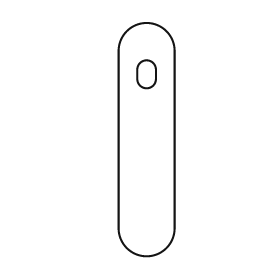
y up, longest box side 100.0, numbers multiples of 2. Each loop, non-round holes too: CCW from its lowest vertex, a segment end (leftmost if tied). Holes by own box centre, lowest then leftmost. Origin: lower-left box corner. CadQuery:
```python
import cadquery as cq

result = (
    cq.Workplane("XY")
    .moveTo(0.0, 12.0)
    .threePointArc((12.0, 0.0), (24.0, 12.0))
    .lineTo(24.0, 88.0)
    .threePointArc((12.0, 100.0), (0.0, 88.0))
    .close()
    .moveTo(8.0, 76.0)
    .threePointArc((12.0, 72.0), (16.0, 76.0))
    .lineTo(16.0, 80.0)
    .threePointArc((12.0, 84.0), (8.0, 80.0))
    .close()
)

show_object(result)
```